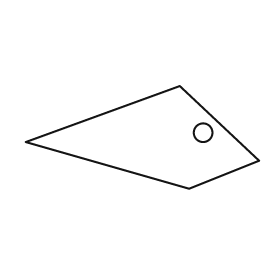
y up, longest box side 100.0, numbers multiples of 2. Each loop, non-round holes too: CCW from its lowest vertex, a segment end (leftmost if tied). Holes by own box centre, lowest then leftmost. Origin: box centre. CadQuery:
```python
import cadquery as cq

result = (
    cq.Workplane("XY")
    .moveTo(20.0, -22.0)
    .lineTo(50.0, -10.0)
    .lineTo(16.0, 22.0)
    .lineTo(-50.0, -2.0)
    .close()
    .moveTo(26.0, 2.0)
    .circle(4.0)
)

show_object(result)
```